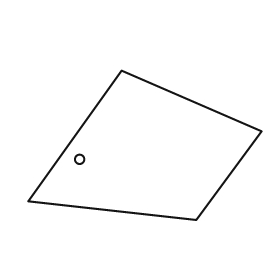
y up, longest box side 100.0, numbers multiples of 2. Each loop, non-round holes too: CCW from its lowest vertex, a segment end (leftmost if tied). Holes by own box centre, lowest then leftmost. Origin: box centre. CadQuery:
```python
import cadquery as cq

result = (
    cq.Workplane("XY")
    .moveTo(22.0, -32.0)
    .lineTo(50.0, 6.0)
    .lineTo(-10.0, 32.0)
    .lineTo(-50.0, -24.0)
    .close()
    .moveTo(-28.0, -6.0)
    .circle(2.0)
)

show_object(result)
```